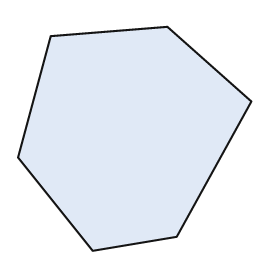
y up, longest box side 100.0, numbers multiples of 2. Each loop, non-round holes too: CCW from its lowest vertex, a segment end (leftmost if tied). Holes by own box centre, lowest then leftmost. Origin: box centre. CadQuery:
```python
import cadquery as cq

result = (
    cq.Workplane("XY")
    .moveTo(-18.0, -48.0)
    .lineTo(18.0, -42.0)
    .lineTo(50.0, 16.0)
    .lineTo(14.0, 48.0)
    .lineTo(-36.0, 44.0)
    .lineTo(-50.0, -8.0)
    .close()
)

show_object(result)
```